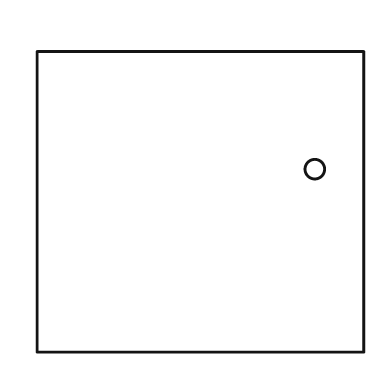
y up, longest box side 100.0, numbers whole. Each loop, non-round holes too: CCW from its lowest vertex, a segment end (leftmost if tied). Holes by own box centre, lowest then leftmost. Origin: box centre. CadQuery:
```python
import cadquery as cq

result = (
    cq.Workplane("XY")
    .moveTo(-50.0, -46.0)
    .lineTo(50.0, -46.0)
    .lineTo(50.0, 46.0)
    .lineTo(-50.0, 46.0)
    .close()
    .moveTo(35.0, 10.0)
    .circle(3.0)
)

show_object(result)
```